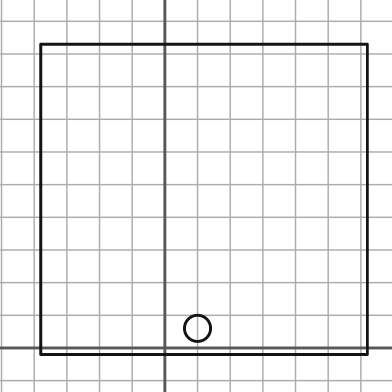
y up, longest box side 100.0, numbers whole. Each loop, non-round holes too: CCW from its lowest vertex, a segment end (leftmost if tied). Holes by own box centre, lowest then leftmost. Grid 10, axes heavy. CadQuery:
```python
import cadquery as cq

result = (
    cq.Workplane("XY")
    .moveTo(-38.0, -2.0)
    .lineTo(62.0, -2.0)
    .lineTo(62.0, 93.0)
    .lineTo(-38.0, 93.0)
    .close()
    .moveTo(10.0, 6.0)
    .circle(4.0)
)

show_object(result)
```